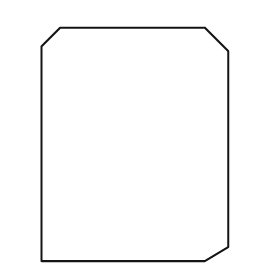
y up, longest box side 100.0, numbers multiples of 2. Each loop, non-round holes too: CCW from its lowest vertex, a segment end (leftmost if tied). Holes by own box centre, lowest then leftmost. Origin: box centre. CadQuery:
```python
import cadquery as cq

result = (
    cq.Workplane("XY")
    .moveTo(-40.0, -50.0)
    .lineTo(30.0, -50.0)
    .lineTo(40.0, -44.0)
    .lineTo(40.0, 40.0)
    .lineTo(30.0, 50.0)
    .lineTo(-32.0, 50.0)
    .lineTo(-40.0, 42.0)
    .close()
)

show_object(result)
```